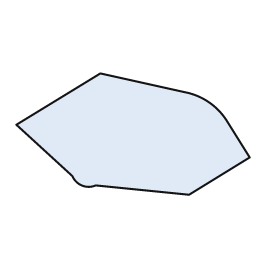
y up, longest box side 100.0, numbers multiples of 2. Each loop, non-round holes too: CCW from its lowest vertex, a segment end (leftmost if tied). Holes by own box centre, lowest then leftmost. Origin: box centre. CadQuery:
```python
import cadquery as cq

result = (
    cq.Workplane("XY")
    .moveTo(24.0, -26.0)
    .lineTo(50.0, -10.0)
    .lineTo(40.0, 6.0)
    .threePointArc((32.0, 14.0), (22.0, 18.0))
    .lineTo(-14.0, 26.0)
    .lineTo(-50.0, 4.0)
    .lineTo(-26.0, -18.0)
    .threePointArc((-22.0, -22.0), (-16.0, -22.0))
    .close()
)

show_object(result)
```